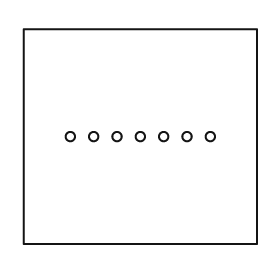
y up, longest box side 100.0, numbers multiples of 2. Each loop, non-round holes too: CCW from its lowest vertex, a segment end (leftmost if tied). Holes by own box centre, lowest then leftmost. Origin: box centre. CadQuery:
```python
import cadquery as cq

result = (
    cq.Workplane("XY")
    .moveTo(-50.0, -46.0)
    .lineTo(50.0, -46.0)
    .lineTo(50.0, 46.0)
    .lineTo(-50.0, 46.0)
    .close()
    .moveTo(-30.0, 0.0)
    .circle(2.0)
    .moveTo(-20.0, 0.0)
    .circle(2.0)
    .moveTo(-10.0, 0.0)
    .circle(2.0)
    .moveTo(0.0, 0.0)
    .circle(2.0)
    .moveTo(10.0, 0.0)
    .circle(2.0)
    .moveTo(20.0, 0.0)
    .circle(2.0)
    .moveTo(30.0, 0.0)
    .circle(2.0)
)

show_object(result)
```